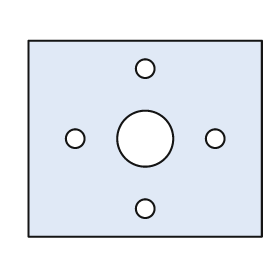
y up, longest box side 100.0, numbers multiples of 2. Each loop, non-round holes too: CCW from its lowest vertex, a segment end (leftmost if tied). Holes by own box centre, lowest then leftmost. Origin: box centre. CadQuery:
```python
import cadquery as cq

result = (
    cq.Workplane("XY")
    .moveTo(-50.0, -42.0)
    .lineTo(50.0, -42.0)
    .lineTo(50.0, 42.0)
    .lineTo(-50.0, 42.0)
    .close()
    .moveTo(0.0, -30.0)
    .circle(4.0)
    .moveTo(-30.0, 0.0)
    .circle(4.0)
    .moveTo(0.0, 0.0)
    .circle(12.0)
    .moveTo(30.0, 0.0)
    .circle(4.0)
    .moveTo(0.0, 30.0)
    .circle(4.0)
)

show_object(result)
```